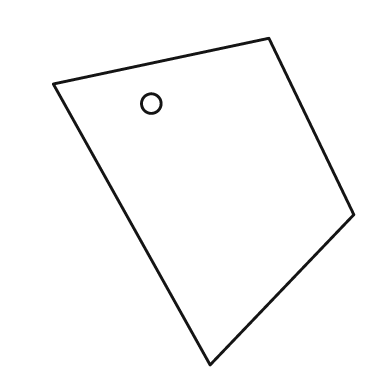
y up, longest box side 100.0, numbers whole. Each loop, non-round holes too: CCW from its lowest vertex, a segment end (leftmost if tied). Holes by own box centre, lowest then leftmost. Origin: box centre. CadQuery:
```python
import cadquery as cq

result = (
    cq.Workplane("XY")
    .moveTo(2.0, -50.0)
    .lineTo(46.0, -4.0)
    .lineTo(20.0, 50.0)
    .lineTo(-46.0, 36.0)
    .close()
    .moveTo(-16.0, 30.0)
    .circle(3.0)
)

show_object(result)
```